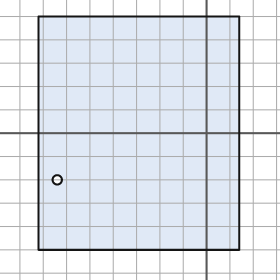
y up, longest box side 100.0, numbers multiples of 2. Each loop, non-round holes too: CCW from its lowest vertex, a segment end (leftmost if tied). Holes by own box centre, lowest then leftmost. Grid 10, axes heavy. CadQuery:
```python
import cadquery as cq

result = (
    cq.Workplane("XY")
    .moveTo(-72.0, -50.0)
    .lineTo(14.0, -50.0)
    .lineTo(14.0, 50.0)
    .lineTo(-72.0, 50.0)
    .close()
    .moveTo(-64.0, -20.0)
    .circle(2.0)
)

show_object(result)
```